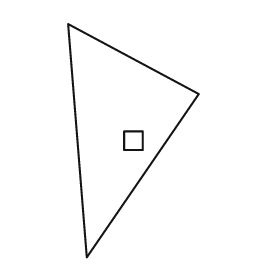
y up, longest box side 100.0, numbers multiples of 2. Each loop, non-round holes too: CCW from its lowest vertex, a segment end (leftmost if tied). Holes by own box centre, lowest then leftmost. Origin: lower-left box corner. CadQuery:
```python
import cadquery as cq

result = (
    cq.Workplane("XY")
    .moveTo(8.0, 0.0)
    .lineTo(56.0, 70.0)
    .lineTo(0.0, 100.0)
    .close()
    .moveTo(24.0, 46.0)
    .lineTo(32.0, 46.0)
    .lineTo(32.0, 54.0)
    .lineTo(24.0, 54.0)
    .close()
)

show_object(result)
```